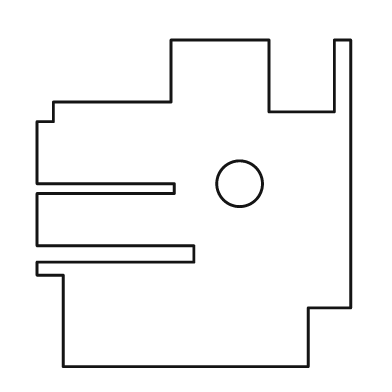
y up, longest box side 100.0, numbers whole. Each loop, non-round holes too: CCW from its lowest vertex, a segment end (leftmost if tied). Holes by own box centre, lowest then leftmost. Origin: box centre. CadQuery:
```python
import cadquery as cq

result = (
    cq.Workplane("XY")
    .moveTo(-40.0, -50.0)
    .lineTo(35.0, -50.0)
    .lineTo(35.0, -32.0)
    .lineTo(48.0, -32.0)
    .lineTo(48.0, 50.0)
    .lineTo(43.0, 50.0)
    .lineTo(43.0, 28.0)
    .lineTo(23.0, 28.0)
    .lineTo(23.0, 50.0)
    .lineTo(-7.0, 50.0)
    .lineTo(-7.0, 31.0)
    .lineTo(-43.0, 31.0)
    .lineTo(-43.0, 25.0)
    .lineTo(-48.0, 25.0)
    .lineTo(-48.0, 6.0)
    .lineTo(-6.0, 6.0)
    .lineTo(-6.0, 3.0)
    .lineTo(-48.0, 3.0)
    .lineTo(-48.0, -13.0)
    .lineTo(0.0, -13.0)
    .lineTo(0.0, -18.0)
    .lineTo(-48.0, -18.0)
    .lineTo(-48.0, -22.0)
    .lineTo(-40.0, -22.0)
    .close()
    .moveTo(14.0, 6.0)
    .circle(7.0)
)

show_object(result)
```